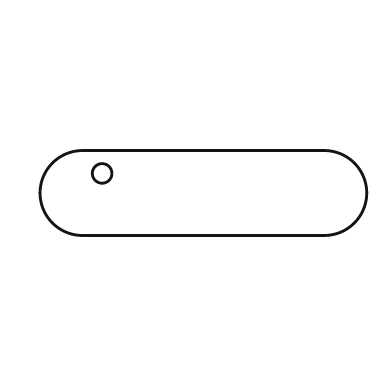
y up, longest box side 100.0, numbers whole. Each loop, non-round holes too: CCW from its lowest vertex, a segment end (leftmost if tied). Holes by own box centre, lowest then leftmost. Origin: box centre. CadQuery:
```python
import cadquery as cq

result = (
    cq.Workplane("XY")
    .moveTo(-37.0, -13.0)
    .lineTo(37.0, -13.0)
    .threePointArc((50.0, 0.0), (37.0, 13.0))
    .lineTo(-37.0, 13.0)
    .threePointArc((-50.0, 0.0), (-37.0, -13.0))
    .close()
    .moveTo(-31.0, 6.0)
    .circle(3.0)
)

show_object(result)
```